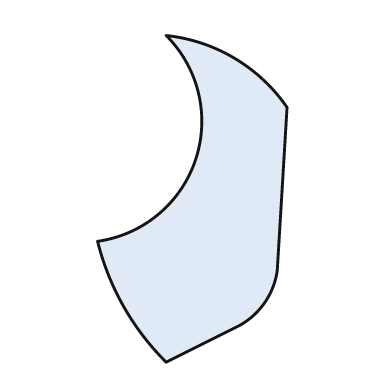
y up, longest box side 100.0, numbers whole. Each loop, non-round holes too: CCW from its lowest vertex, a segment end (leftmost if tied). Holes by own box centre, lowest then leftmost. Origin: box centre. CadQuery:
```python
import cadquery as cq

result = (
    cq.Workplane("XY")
    .moveTo(-8.0, -50.0)
    .lineTo(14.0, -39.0)
    .threePointArc((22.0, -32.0), (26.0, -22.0))
    .lineTo(29.0, 28.0)
    .threePointArc((13.0, 43.0), (-8.0, 50.0))
    .threePointArc((1.0, 12.0), (-29.0, -13.0))
    .threePointArc((-21.0, -33.0), (-8.0, -50.0))
    .close()
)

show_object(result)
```